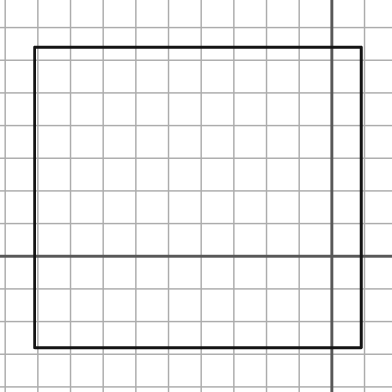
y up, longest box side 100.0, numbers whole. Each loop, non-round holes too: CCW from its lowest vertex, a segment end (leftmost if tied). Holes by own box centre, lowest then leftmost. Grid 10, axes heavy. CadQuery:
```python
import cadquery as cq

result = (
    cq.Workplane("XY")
    .moveTo(-91.0, -28.0)
    .lineTo(9.0, -28.0)
    .lineTo(9.0, 64.0)
    .lineTo(-91.0, 64.0)
    .close()
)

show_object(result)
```